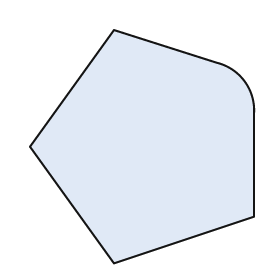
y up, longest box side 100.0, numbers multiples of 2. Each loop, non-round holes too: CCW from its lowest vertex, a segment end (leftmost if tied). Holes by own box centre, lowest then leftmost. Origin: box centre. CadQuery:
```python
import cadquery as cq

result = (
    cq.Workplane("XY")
    .moveTo(-12.0, -50.0)
    .lineTo(48.0, -30.0)
    .lineTo(48.0, 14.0)
    .threePointArc((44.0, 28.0), (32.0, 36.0))
    .lineTo(-12.0, 50.0)
    .lineTo(-48.0, 0.0)
    .close()
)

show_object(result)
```